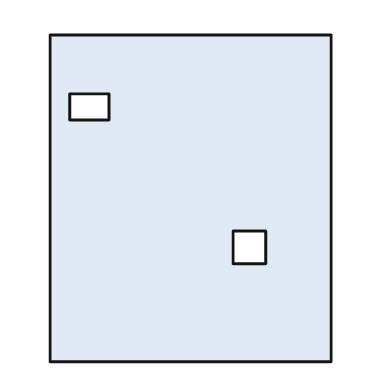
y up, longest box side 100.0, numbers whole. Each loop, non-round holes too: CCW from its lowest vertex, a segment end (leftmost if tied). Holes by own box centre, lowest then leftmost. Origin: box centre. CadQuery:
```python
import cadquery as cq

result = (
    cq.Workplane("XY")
    .moveTo(-43.0, -50.0)
    .lineTo(43.0, -50.0)
    .lineTo(43.0, 50.0)
    .lineTo(-43.0, 50.0)
    .close()
    .moveTo(13.0, -20.0)
    .lineTo(23.0, -20.0)
    .lineTo(23.0, -10.0)
    .lineTo(13.0, -10.0)
    .close()
    .moveTo(-37.0, 24.0)
    .lineTo(-25.0, 24.0)
    .lineTo(-25.0, 32.0)
    .lineTo(-37.0, 32.0)
    .close()
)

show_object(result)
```